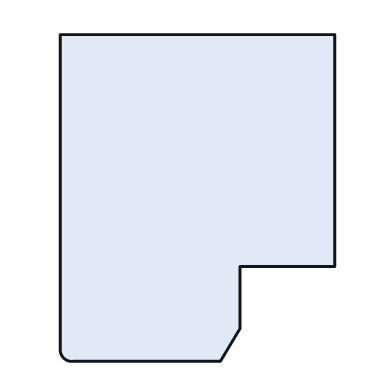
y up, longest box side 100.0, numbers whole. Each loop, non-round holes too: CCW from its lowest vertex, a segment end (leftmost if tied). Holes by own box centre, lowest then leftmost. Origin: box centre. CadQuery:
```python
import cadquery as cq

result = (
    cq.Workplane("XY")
    .moveTo(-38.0, -50.0)
    .lineTo(7.0, -50.0)
    .lineTo(13.0, -40.0)
    .lineTo(13.0, -21.0)
    .lineTo(42.0, -21.0)
    .lineTo(42.0, 50.0)
    .lineTo(-42.0, 50.0)
    .lineTo(-42.0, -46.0)
    .threePointArc((-41.0, -49.0), (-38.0, -50.0))
    .close()
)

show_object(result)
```